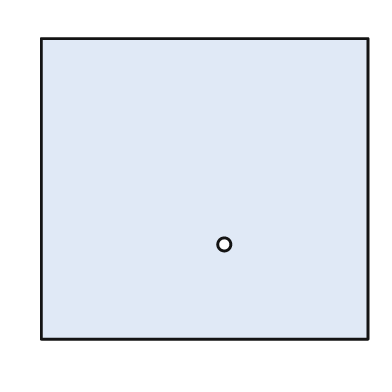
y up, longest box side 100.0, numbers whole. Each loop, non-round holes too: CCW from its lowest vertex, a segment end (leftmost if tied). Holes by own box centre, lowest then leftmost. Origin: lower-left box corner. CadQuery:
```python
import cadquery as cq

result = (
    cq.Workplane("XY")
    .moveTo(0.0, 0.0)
    .lineTo(100.0, 0.0)
    .lineTo(100.0, 92.0)
    .lineTo(0.0, 92.0)
    .close()
    .moveTo(56.0, 29.0)
    .circle(2.0)
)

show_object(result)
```